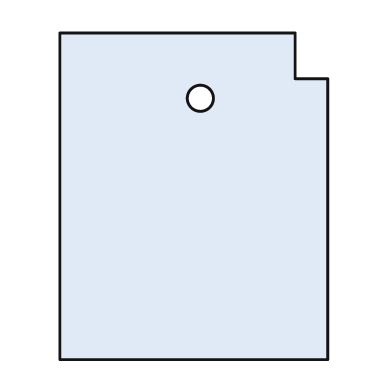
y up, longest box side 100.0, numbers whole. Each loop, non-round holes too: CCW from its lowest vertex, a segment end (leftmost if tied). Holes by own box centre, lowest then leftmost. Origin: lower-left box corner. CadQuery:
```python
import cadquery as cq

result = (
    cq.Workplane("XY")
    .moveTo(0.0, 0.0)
    .lineTo(82.0, 0.0)
    .lineTo(82.0, 86.0)
    .lineTo(72.0, 86.0)
    .lineTo(72.0, 100.0)
    .lineTo(0.0, 100.0)
    .close()
    .moveTo(43.0, 80.0)
    .circle(4.0)
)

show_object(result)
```